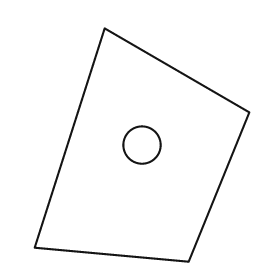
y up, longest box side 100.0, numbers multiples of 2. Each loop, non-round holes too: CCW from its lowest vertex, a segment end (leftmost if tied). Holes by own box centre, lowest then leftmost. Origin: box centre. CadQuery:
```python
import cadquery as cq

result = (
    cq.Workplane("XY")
    .moveTo(20.0, -50.0)
    .lineTo(46.0, 14.0)
    .lineTo(-16.0, 50.0)
    .lineTo(-46.0, -44.0)
    .close()
    .moveTo(0.0, 0.0)
    .circle(8.0)
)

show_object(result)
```